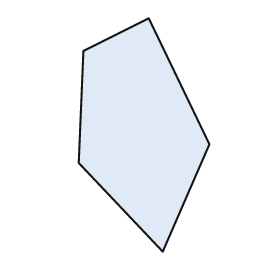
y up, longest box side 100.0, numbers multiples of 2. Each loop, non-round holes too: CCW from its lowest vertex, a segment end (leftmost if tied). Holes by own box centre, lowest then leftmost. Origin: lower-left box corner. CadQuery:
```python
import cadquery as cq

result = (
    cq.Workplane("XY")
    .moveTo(36.0, 0.0)
    .lineTo(56.0, 46.0)
    .lineTo(30.0, 100.0)
    .lineTo(2.0, 86.0)
    .lineTo(0.0, 38.0)
    .close()
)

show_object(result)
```